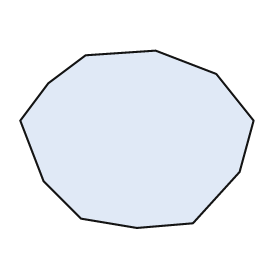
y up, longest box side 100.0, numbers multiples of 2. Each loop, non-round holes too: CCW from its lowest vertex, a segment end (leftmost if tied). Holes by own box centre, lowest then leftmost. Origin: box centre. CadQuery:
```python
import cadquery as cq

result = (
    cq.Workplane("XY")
    .moveTo(0.0, -38.0)
    .lineTo(24.0, -36.0)
    .lineTo(44.0, -14.0)
    .lineTo(50.0, 8.0)
    .lineTo(34.0, 28.0)
    .lineTo(8.0, 38.0)
    .lineTo(-22.0, 36.0)
    .lineTo(-38.0, 24.0)
    .lineTo(-50.0, 8.0)
    .lineTo(-40.0, -18.0)
    .lineTo(-24.0, -34.0)
    .close()
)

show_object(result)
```